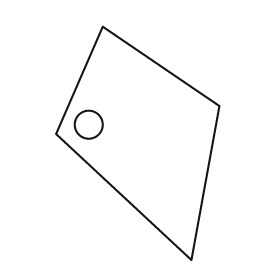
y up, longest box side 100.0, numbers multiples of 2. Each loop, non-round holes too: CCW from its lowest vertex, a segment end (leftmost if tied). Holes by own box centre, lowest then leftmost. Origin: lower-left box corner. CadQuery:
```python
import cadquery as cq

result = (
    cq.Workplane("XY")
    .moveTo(58.0, 0.0)
    .lineTo(70.0, 66.0)
    .lineTo(20.0, 100.0)
    .lineTo(0.0, 54.0)
    .close()
    .moveTo(14.0, 58.0)
    .circle(6.0)
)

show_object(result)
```